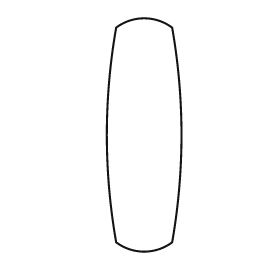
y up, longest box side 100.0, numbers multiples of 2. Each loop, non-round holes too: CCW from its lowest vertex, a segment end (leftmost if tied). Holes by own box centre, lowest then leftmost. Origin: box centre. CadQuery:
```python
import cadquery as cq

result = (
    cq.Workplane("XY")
    .moveTo(-12.0, -46.0)
    .threePointArc((0.0, -50.0), (12.0, -46.0))
    .threePointArc((16.0, 0.0), (12.0, 46.0))
    .threePointArc((0.0, 50.0), (-12.0, 46.0))
    .threePointArc((-16.0, 0.0), (-12.0, -46.0))
    .close()
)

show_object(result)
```